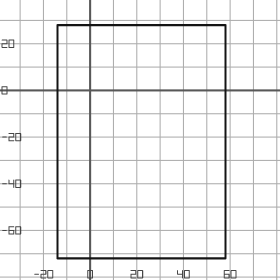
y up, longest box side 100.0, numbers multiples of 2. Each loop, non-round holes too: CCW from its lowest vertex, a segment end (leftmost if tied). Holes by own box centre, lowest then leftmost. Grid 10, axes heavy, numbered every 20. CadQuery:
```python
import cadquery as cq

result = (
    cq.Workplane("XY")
    .moveTo(-14.0, -72.0)
    .lineTo(58.0, -72.0)
    .lineTo(58.0, 28.0)
    .lineTo(-14.0, 28.0)
    .close()
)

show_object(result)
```